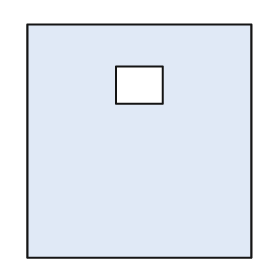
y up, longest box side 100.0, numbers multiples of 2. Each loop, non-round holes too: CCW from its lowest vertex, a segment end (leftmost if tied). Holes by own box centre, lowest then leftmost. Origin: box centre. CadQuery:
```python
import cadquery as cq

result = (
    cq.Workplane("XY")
    .moveTo(-48.0, -50.0)
    .lineTo(48.0, -50.0)
    .lineTo(48.0, 50.0)
    .lineTo(-48.0, 50.0)
    .close()
    .moveTo(-10.0, 16.0)
    .lineTo(10.0, 16.0)
    .lineTo(10.0, 32.0)
    .lineTo(-10.0, 32.0)
    .close()
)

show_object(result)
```